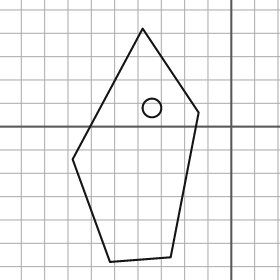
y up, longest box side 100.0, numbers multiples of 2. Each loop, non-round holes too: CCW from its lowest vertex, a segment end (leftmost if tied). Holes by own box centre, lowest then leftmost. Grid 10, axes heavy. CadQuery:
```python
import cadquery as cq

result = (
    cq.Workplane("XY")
    .moveTo(-52.0, -58.0)
    .lineTo(-26.0, -56.0)
    .lineTo(-14.0, 6.0)
    .lineTo(-38.0, 42.0)
    .lineTo(-68.0, -14.0)
    .close()
    .moveTo(-34.0, 8.0)
    .circle(4.0)
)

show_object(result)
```